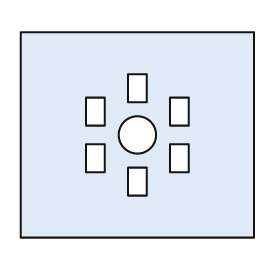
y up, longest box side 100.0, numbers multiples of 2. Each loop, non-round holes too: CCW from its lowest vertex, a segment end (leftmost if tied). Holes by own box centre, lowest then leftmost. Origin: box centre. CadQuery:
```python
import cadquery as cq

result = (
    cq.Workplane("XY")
    .moveTo(-50.0, -44.0)
    .lineTo(50.0, -44.0)
    .lineTo(50.0, 44.0)
    .lineTo(-50.0, 44.0)
    .close()
    .moveTo(-4.0, -26.0)
    .lineTo(4.0, -26.0)
    .lineTo(4.0, -14.0)
    .lineTo(-4.0, -14.0)
    .close()
    .moveTo(-22.0, -16.0)
    .lineTo(-14.0, -16.0)
    .lineTo(-14.0, -4.0)
    .lineTo(-22.0, -4.0)
    .close()
    .moveTo(14.0, -16.0)
    .lineTo(22.0, -16.0)
    .lineTo(22.0, -4.0)
    .lineTo(14.0, -4.0)
    .close()
    .moveTo(0.0, 0.0)
    .circle(8.0)
    .moveTo(-22.0, 4.0)
    .lineTo(-14.0, 4.0)
    .lineTo(-14.0, 16.0)
    .lineTo(-22.0, 16.0)
    .close()
    .moveTo(14.0, 4.0)
    .lineTo(22.0, 4.0)
    .lineTo(22.0, 16.0)
    .lineTo(14.0, 16.0)
    .close()
    .moveTo(-4.0, 14.0)
    .lineTo(4.0, 14.0)
    .lineTo(4.0, 26.0)
    .lineTo(-4.0, 26.0)
    .close()
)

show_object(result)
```